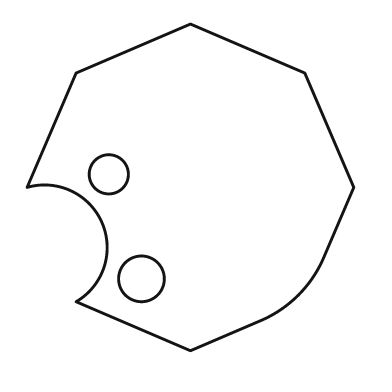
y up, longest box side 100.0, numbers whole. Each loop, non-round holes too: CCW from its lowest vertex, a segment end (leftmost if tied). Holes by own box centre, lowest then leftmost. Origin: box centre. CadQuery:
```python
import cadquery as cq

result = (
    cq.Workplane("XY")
    .moveTo(0.0, -50.0)
    .lineTo(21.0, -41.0)
    .threePointArc((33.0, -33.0), (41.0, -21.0))
    .lineTo(50.0, 0.0)
    .lineTo(35.0, 35.0)
    .lineTo(0.0, 50.0)
    .lineTo(-35.0, 35.0)
    .lineTo(-50.0, 0.0)
    .threePointArc((-27.0, -11.0), (-35.0, -35.0))
    .close()
    .moveTo(-15.0, -28.0)
    .circle(7.0)
    .moveTo(-25.0, 4.0)
    .circle(6.0)
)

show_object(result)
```